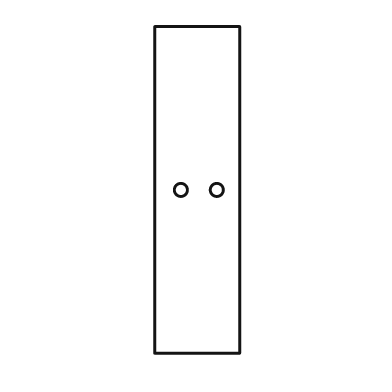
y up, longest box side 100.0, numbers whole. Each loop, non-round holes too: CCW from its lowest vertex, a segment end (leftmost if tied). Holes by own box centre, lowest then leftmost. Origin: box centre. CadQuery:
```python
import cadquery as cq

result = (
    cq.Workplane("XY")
    .moveTo(-13.0, -50.0)
    .lineTo(13.0, -50.0)
    .lineTo(13.0, 50.0)
    .lineTo(-13.0, 50.0)
    .close()
    .moveTo(-5.0, 0.0)
    .circle(2.0)
    .moveTo(6.0, 0.0)
    .circle(2.0)
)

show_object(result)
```